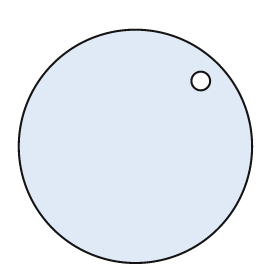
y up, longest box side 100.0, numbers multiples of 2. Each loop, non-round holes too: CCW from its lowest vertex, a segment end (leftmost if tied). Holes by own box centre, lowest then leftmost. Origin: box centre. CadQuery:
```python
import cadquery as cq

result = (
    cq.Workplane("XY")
    .moveTo(0.0, 0.0)
    .circle(50.0)
    .moveTo(28.0, 28.0)
    .circle(4.0)
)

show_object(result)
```